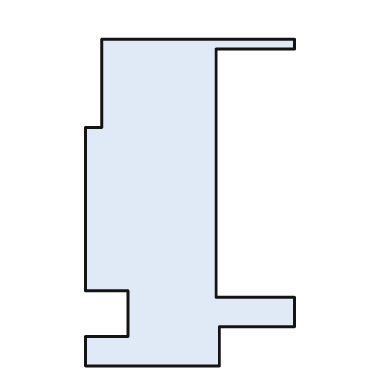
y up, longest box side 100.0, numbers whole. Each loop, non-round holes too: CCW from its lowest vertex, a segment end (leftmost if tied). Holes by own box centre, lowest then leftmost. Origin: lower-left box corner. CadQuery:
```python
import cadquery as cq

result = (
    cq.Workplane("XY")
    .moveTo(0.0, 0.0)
    .lineTo(41.0, 0.0)
    .lineTo(41.0, 12.0)
    .lineTo(64.0, 12.0)
    .lineTo(64.0, 21.0)
    .lineTo(40.0, 21.0)
    .lineTo(40.0, 97.0)
    .lineTo(64.0, 97.0)
    .lineTo(64.0, 100.0)
    .lineTo(5.0, 100.0)
    .lineTo(5.0, 73.0)
    .lineTo(0.0, 73.0)
    .lineTo(0.0, 23.0)
    .lineTo(13.0, 23.0)
    .lineTo(13.0, 9.0)
    .lineTo(0.0, 9.0)
    .close()
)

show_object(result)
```